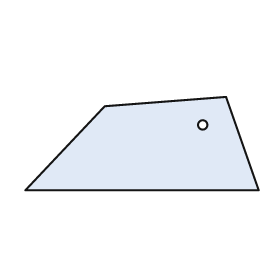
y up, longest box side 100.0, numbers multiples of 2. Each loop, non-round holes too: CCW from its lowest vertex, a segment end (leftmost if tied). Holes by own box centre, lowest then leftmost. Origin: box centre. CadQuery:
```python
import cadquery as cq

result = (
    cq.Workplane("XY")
    .moveTo(-50.0, -20.0)
    .lineTo(50.0, -20.0)
    .lineTo(36.0, 20.0)
    .lineTo(-16.0, 16.0)
    .close()
    .moveTo(26.0, 8.0)
    .circle(2.0)
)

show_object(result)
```